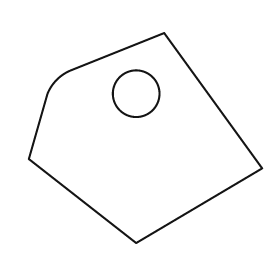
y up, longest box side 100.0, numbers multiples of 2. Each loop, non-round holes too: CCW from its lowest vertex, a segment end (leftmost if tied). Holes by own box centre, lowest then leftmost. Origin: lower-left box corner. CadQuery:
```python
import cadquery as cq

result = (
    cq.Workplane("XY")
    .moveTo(46.0, 0.0)
    .lineTo(100.0, 32.0)
    .lineTo(58.0, 90.0)
    .lineTo(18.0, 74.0)
    .threePointArc((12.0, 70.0), (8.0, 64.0))
    .lineTo(0.0, 36.0)
    .close()
    .moveTo(46.0, 64.0)
    .circle(10.0)
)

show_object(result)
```